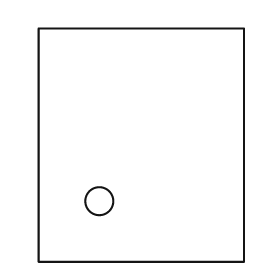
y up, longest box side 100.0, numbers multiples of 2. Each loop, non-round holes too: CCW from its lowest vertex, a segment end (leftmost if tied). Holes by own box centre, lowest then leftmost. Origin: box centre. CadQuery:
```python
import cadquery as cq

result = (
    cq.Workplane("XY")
    .moveTo(-44.0, -50.0)
    .lineTo(44.0, -50.0)
    .lineTo(44.0, 50.0)
    .lineTo(-44.0, 50.0)
    .close()
    .moveTo(-18.0, -24.0)
    .circle(6.0)
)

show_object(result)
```